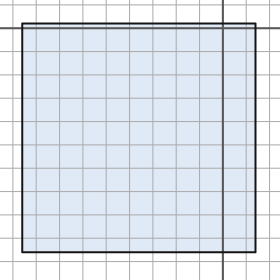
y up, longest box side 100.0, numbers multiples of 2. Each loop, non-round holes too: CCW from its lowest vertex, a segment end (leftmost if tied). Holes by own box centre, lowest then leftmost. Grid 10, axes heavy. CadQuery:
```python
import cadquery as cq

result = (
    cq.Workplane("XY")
    .moveTo(-86.0, -96.0)
    .lineTo(14.0, -96.0)
    .lineTo(14.0, 2.0)
    .lineTo(-86.0, 2.0)
    .close()
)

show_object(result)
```